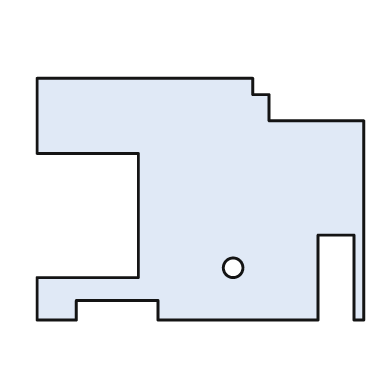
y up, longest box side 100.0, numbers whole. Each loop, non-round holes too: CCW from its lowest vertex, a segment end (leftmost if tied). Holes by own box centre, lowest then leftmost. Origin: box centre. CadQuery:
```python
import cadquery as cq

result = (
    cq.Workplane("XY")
    .moveTo(-50.0, -37.0)
    .lineTo(-38.0, -37.0)
    .lineTo(-38.0, -31.0)
    .lineTo(-13.0, -31.0)
    .lineTo(-13.0, -37.0)
    .lineTo(36.0, -37.0)
    .lineTo(36.0, -11.0)
    .lineTo(47.0, -11.0)
    .lineTo(47.0, -37.0)
    .lineTo(50.0, -37.0)
    .lineTo(50.0, 24.0)
    .lineTo(21.0, 24.0)
    .lineTo(21.0, 32.0)
    .lineTo(16.0, 32.0)
    .lineTo(16.0, 37.0)
    .lineTo(-50.0, 37.0)
    .lineTo(-50.0, 14.0)
    .lineTo(-19.0, 14.0)
    .lineTo(-19.0, -24.0)
    .lineTo(-50.0, -24.0)
    .close()
    .moveTo(10.0, -21.0)
    .circle(3.0)
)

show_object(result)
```